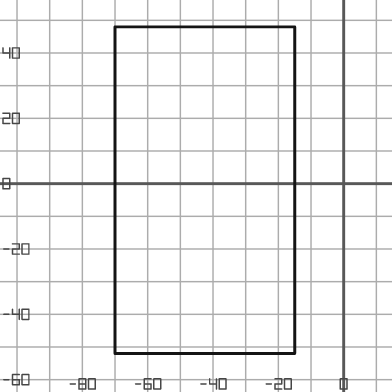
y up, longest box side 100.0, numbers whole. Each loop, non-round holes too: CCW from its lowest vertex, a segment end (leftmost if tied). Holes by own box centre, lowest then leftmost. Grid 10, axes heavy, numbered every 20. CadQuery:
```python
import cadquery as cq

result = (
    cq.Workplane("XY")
    .moveTo(-70.0, -52.0)
    .lineTo(-15.0, -52.0)
    .lineTo(-15.0, 48.0)
    .lineTo(-70.0, 48.0)
    .close()
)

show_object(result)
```